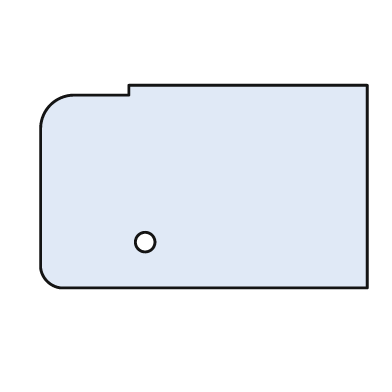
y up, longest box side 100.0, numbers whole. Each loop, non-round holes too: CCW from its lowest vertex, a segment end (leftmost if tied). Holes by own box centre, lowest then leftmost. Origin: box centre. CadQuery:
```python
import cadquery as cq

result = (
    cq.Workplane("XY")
    .moveTo(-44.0, -31.0)
    .lineTo(50.0, -31.0)
    .lineTo(50.0, 31.0)
    .lineTo(-23.0, 31.0)
    .lineTo(-23.0, 28.0)
    .lineTo(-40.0, 28.0)
    .threePointArc((-47.0, 25.0), (-50.0, 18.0))
    .lineTo(-50.0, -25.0)
    .threePointArc((-48.0, -29.0), (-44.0, -31.0))
    .close()
    .moveTo(-18.0, -17.0)
    .circle(3.0)
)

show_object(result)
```